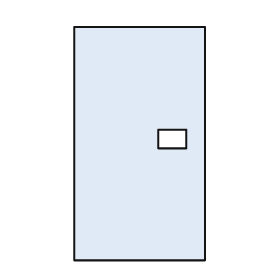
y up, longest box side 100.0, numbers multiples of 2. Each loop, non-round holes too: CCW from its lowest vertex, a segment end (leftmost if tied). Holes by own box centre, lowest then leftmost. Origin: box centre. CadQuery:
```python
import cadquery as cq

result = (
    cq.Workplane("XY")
    .moveTo(-28.0, -50.0)
    .lineTo(28.0, -50.0)
    .lineTo(28.0, 50.0)
    .lineTo(-28.0, 50.0)
    .close()
    .moveTo(8.0, -2.0)
    .lineTo(20.0, -2.0)
    .lineTo(20.0, 6.0)
    .lineTo(8.0, 6.0)
    .close()
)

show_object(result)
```